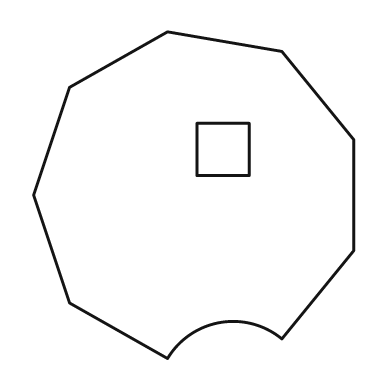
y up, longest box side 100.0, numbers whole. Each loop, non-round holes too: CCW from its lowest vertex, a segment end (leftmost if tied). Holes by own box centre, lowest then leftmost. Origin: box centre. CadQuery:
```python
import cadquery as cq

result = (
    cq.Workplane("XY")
    .moveTo(-8.0, -50.0)
    .threePointArc((8.0, -39.0), (27.0, -44.0))
    .lineTo(49.0, -17.0)
    .lineTo(49.0, 17.0)
    .lineTo(27.0, 44.0)
    .lineTo(-8.0, 50.0)
    .lineTo(-38.0, 33.0)
    .lineTo(-49.0, 0.0)
    .lineTo(-38.0, -33.0)
    .close()
    .moveTo(1.0, 6.0)
    .lineTo(17.0, 6.0)
    .lineTo(17.0, 22.0)
    .lineTo(1.0, 22.0)
    .close()
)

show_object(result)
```